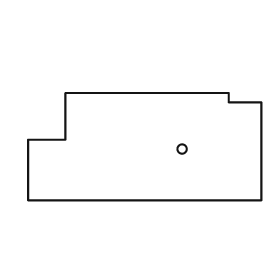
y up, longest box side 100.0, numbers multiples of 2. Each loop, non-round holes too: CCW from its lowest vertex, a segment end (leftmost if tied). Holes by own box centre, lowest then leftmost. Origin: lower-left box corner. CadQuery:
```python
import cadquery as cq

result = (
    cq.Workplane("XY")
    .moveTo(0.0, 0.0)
    .lineTo(100.0, 0.0)
    .lineTo(100.0, 42.0)
    .lineTo(86.0, 42.0)
    .lineTo(86.0, 46.0)
    .lineTo(16.0, 46.0)
    .lineTo(16.0, 26.0)
    .lineTo(0.0, 26.0)
    .close()
    .moveTo(66.0, 22.0)
    .circle(2.0)
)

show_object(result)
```